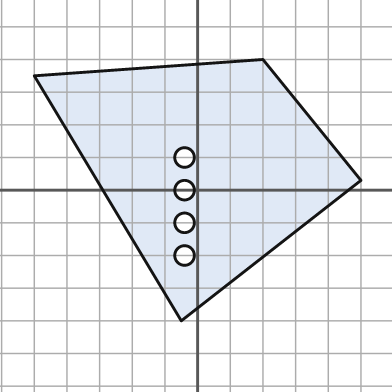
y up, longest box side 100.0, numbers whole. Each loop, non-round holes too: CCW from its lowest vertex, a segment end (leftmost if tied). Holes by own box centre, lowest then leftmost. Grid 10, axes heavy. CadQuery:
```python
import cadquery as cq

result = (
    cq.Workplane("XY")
    .moveTo(-5.0, -40.0)
    .lineTo(50.0, 3.0)
    .lineTo(20.0, 40.0)
    .lineTo(-50.0, 35.0)
    .close()
    .moveTo(-4.0, -20.0)
    .circle(3.0)
    .moveTo(-4.0, -10.0)
    .circle(3.0)
    .moveTo(-4.0, 0.0)
    .circle(3.0)
    .moveTo(-4.0, 10.0)
    .circle(3.0)
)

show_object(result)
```